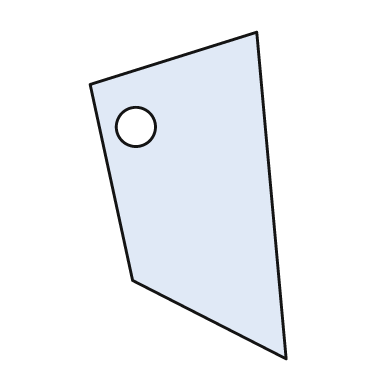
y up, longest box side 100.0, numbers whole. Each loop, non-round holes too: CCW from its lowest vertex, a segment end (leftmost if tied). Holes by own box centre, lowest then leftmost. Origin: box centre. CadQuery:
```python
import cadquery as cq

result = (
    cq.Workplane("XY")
    .moveTo(30.0, -50.0)
    .lineTo(21.0, 50.0)
    .lineTo(-30.0, 34.0)
    .lineTo(-17.0, -26.0)
    .close()
    .moveTo(-16.0, 21.0)
    .circle(6.0)
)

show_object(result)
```